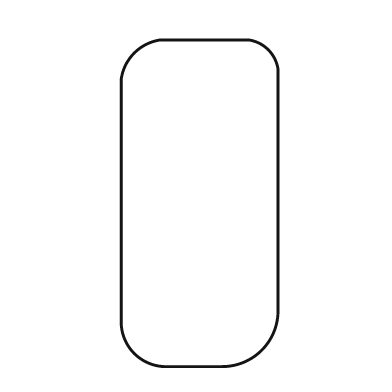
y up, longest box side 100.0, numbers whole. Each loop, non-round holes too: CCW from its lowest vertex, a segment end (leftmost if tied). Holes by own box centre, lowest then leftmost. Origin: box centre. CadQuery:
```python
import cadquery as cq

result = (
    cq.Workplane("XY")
    .moveTo(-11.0, -50.0)
    .lineTo(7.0, -50.0)
    .threePointArc((19.0, -45.0), (24.0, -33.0))
    .lineTo(24.0, 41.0)
    .threePointArc((21.0, 47.0), (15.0, 50.0))
    .lineTo(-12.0, 50.0)
    .threePointArc((-20.0, 46.0), (-24.0, 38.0))
    .lineTo(-24.0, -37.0)
    .threePointArc((-20.0, -46.0), (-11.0, -50.0))
    .close()
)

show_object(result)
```